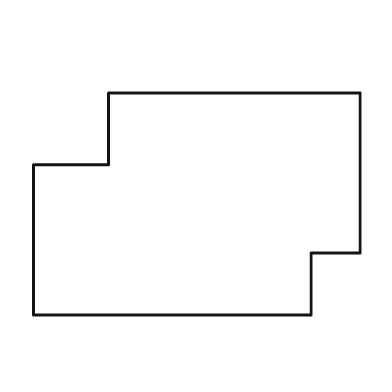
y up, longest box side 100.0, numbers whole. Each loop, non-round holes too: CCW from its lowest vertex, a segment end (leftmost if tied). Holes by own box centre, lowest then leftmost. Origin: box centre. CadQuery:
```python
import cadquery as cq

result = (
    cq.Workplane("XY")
    .moveTo(-50.0, -34.0)
    .lineTo(35.0, -34.0)
    .lineTo(35.0, -15.0)
    .lineTo(50.0, -15.0)
    .lineTo(50.0, 34.0)
    .lineTo(-27.0, 34.0)
    .lineTo(-27.0, 12.0)
    .lineTo(-50.0, 12.0)
    .close()
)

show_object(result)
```